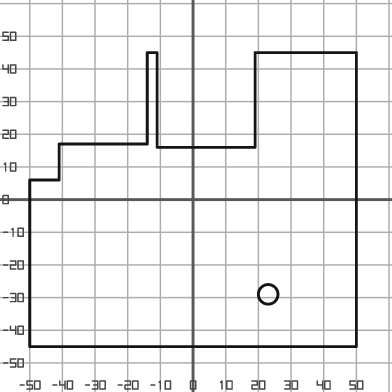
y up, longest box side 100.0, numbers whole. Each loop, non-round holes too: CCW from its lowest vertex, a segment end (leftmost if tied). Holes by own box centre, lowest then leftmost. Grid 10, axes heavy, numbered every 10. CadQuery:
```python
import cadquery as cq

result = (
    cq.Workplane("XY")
    .moveTo(-50.0, -45.0)
    .lineTo(50.0, -45.0)
    .lineTo(50.0, 45.0)
    .lineTo(19.0, 45.0)
    .lineTo(19.0, 16.0)
    .lineTo(-11.0, 16.0)
    .lineTo(-11.0, 45.0)
    .lineTo(-14.0, 45.0)
    .lineTo(-14.0, 17.0)
    .lineTo(-41.0, 17.0)
    .lineTo(-41.0, 6.0)
    .lineTo(-50.0, 6.0)
    .close()
    .moveTo(23.0, -29.0)
    .circle(3.0)
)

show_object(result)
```